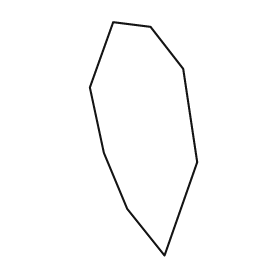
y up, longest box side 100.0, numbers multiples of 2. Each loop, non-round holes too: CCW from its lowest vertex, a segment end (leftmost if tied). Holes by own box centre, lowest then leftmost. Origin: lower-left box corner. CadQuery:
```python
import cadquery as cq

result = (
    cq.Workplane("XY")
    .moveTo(32.0, 0.0)
    .lineTo(46.0, 40.0)
    .lineTo(40.0, 80.0)
    .lineTo(26.0, 98.0)
    .lineTo(10.0, 100.0)
    .lineTo(0.0, 72.0)
    .lineTo(6.0, 44.0)
    .lineTo(16.0, 20.0)
    .close()
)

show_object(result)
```